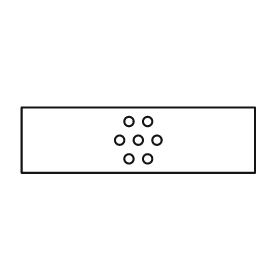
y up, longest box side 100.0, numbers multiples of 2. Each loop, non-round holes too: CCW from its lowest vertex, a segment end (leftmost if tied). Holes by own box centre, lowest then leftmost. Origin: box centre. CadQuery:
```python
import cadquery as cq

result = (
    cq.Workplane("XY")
    .moveTo(-50.0, -14.0)
    .lineTo(50.0, -14.0)
    .lineTo(50.0, 14.0)
    .lineTo(-50.0, 14.0)
    .close()
    .moveTo(-4.0, -8.0)
    .circle(2.0)
    .moveTo(4.0, -8.0)
    .circle(2.0)
    .moveTo(-8.0, 0.0)
    .circle(2.0)
    .moveTo(0.0, 0.0)
    .circle(2.0)
    .moveTo(8.0, 0.0)
    .circle(2.0)
    .moveTo(-4.0, 8.0)
    .circle(2.0)
    .moveTo(4.0, 8.0)
    .circle(2.0)
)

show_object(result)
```